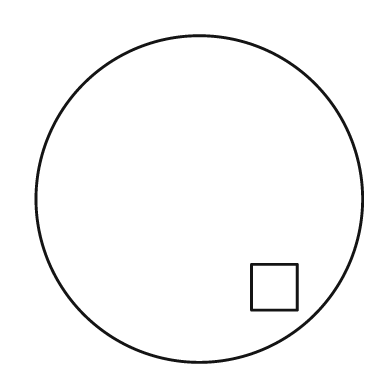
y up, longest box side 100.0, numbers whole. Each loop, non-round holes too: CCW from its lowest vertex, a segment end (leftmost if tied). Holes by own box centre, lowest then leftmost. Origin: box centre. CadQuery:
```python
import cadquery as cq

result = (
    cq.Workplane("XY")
    .moveTo(0.0, 0.0)
    .circle(50.0)
    .moveTo(16.0, -34.0)
    .lineTo(30.0, -34.0)
    .lineTo(30.0, -20.0)
    .lineTo(16.0, -20.0)
    .close()
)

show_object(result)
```